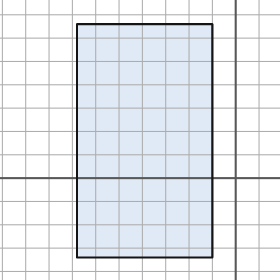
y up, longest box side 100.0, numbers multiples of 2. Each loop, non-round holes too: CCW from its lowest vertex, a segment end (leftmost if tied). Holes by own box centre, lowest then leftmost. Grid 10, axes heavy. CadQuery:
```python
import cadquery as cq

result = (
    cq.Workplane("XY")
    .moveTo(-68.0, -34.0)
    .lineTo(-10.0, -34.0)
    .lineTo(-10.0, 66.0)
    .lineTo(-68.0, 66.0)
    .close()
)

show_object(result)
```